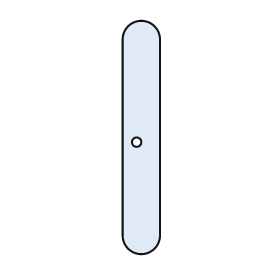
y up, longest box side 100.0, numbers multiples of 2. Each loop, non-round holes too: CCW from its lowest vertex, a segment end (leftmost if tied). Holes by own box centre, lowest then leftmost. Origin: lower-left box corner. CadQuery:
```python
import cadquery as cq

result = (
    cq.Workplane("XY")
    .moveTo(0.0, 8.0)
    .threePointArc((8.0, 0.0), (16.0, 8.0))
    .lineTo(16.0, 92.0)
    .threePointArc((8.0, 100.0), (0.0, 92.0))
    .close()
    .moveTo(6.0, 48.0)
    .circle(2.0)
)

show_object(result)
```